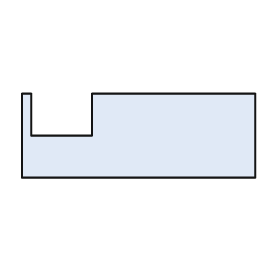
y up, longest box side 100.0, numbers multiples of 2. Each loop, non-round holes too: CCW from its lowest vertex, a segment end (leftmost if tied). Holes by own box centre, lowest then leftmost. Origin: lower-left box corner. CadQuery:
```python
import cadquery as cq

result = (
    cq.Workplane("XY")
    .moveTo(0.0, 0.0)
    .lineTo(100.0, 0.0)
    .lineTo(100.0, 36.0)
    .lineTo(30.0, 36.0)
    .lineTo(30.0, 18.0)
    .lineTo(4.0, 18.0)
    .lineTo(4.0, 36.0)
    .lineTo(0.0, 36.0)
    .close()
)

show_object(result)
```